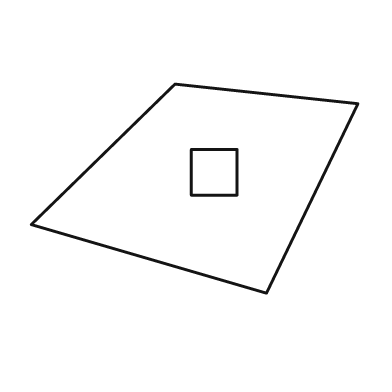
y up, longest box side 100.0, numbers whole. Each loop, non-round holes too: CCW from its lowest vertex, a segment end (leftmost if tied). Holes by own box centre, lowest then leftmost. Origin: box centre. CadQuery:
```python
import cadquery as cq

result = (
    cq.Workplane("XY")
    .moveTo(22.0, -32.0)
    .lineTo(50.0, 26.0)
    .lineTo(-6.0, 32.0)
    .lineTo(-50.0, -11.0)
    .close()
    .moveTo(-1.0, -2.0)
    .lineTo(13.0, -2.0)
    .lineTo(13.0, 12.0)
    .lineTo(-1.0, 12.0)
    .close()
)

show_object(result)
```